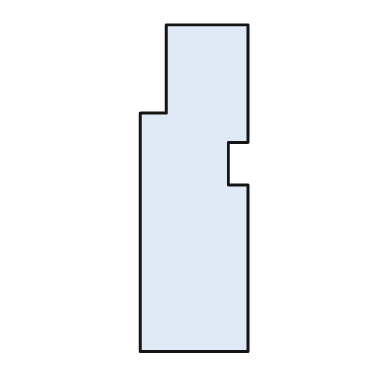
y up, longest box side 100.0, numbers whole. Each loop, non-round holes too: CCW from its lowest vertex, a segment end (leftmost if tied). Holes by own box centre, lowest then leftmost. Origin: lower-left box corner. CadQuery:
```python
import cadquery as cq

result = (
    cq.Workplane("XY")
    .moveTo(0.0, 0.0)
    .lineTo(33.0, 0.0)
    .lineTo(33.0, 51.0)
    .lineTo(27.0, 51.0)
    .lineTo(27.0, 64.0)
    .lineTo(33.0, 64.0)
    .lineTo(33.0, 100.0)
    .lineTo(8.0, 100.0)
    .lineTo(8.0, 73.0)
    .lineTo(0.0, 73.0)
    .close()
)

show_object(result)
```